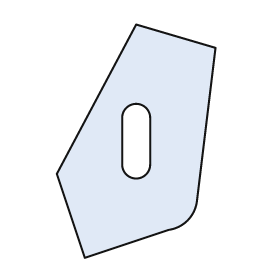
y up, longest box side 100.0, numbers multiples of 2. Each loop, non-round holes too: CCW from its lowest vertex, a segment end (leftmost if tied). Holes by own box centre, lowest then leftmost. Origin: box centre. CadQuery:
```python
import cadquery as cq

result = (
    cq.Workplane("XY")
    .moveTo(-22.0, -50.0)
    .lineTo(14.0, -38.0)
    .threePointArc((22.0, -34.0), (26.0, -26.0))
    .lineTo(34.0, 40.0)
    .lineTo(0.0, 50.0)
    .lineTo(-34.0, -14.0)
    .close()
    .moveTo(-6.0, -10.0)
    .threePointArc((0.0, -16.0), (6.0, -10.0))
    .lineTo(6.0, 10.0)
    .threePointArc((0.0, 16.0), (-6.0, 10.0))
    .close()
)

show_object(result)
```